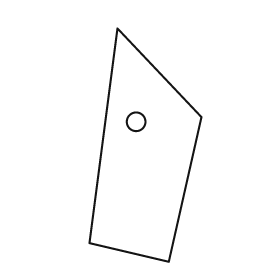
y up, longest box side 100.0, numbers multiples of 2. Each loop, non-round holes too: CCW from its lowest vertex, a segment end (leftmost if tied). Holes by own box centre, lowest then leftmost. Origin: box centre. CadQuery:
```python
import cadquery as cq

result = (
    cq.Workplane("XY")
    .moveTo(10.0, -50.0)
    .lineTo(24.0, 12.0)
    .lineTo(-12.0, 50.0)
    .lineTo(-24.0, -42.0)
    .close()
    .moveTo(-4.0, 10.0)
    .circle(4.0)
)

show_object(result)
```